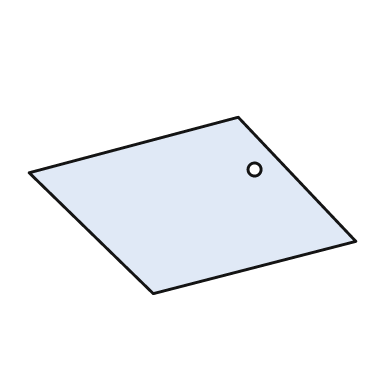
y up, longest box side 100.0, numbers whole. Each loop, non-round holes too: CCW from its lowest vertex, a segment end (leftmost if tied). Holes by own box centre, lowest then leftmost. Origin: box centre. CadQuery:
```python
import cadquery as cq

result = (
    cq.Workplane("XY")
    .moveTo(-12.0, -27.0)
    .lineTo(50.0, -11.0)
    .lineTo(14.0, 27.0)
    .lineTo(-50.0, 10.0)
    .close()
    .moveTo(19.0, 11.0)
    .circle(2.0)
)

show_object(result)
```